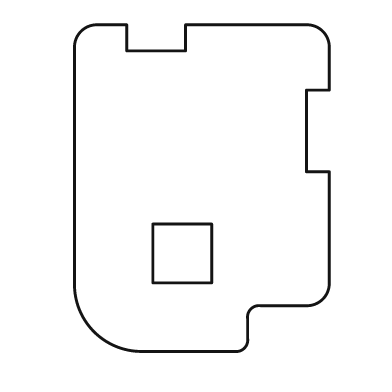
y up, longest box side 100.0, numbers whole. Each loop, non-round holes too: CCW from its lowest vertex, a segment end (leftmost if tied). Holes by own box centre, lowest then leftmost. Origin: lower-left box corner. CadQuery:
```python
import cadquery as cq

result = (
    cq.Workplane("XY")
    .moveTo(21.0, 0.0)
    .lineTo(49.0, 0.0)
    .threePointArc((52.0, 1.0), (53.0, 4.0))
    .lineTo(53.0, 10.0)
    .threePointArc((54.0, 13.0), (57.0, 14.0))
    .lineTo(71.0, 14.0)
    .threePointArc((76.0, 16.0), (78.0, 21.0))
    .lineTo(78.0, 55.0)
    .lineTo(71.0, 55.0)
    .lineTo(71.0, 80.0)
    .lineTo(78.0, 80.0)
    .lineTo(78.0, 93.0)
    .threePointArc((76.0, 98.0), (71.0, 100.0))
    .lineTo(34.0, 100.0)
    .lineTo(34.0, 92.0)
    .lineTo(16.0, 92.0)
    .lineTo(16.0, 100.0)
    .lineTo(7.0, 100.0)
    .threePointArc((2.0, 98.0), (0.0, 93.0))
    .lineTo(0.0, 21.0)
    .threePointArc((6.0, 6.0), (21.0, 0.0))
    .close()
    .moveTo(24.0, 21.0)
    .lineTo(42.0, 21.0)
    .lineTo(42.0, 39.0)
    .lineTo(24.0, 39.0)
    .close()
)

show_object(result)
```